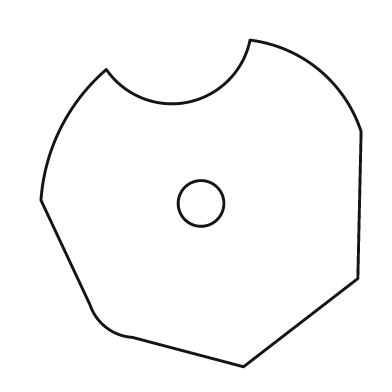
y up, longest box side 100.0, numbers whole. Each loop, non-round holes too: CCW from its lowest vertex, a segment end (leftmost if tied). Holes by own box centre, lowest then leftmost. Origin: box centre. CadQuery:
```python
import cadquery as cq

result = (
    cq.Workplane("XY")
    .moveTo(13.0, -50.0)
    .lineTo(48.0, -23.0)
    .lineTo(49.0, 22.0)
    .threePointArc((36.0, 41.0), (15.0, 50.0))
    .threePointArc((-4.0, 31.0), (-29.0, 41.0))
    .threePointArc((-43.0, 23.0), (-49.0, 1.0))
    .lineTo(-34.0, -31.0)
    .threePointArc((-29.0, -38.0), (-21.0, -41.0))
    .close()
    .moveTo(0.0, 0.0)
    .circle(7.0)
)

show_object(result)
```